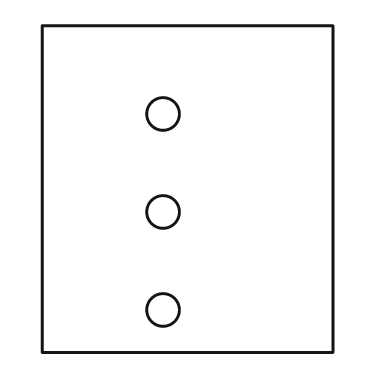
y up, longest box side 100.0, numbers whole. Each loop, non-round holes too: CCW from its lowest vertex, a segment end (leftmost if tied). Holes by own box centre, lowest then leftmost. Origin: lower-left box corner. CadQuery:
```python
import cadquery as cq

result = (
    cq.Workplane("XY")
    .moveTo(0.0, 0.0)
    .lineTo(89.0, 0.0)
    .lineTo(89.0, 100.0)
    .lineTo(0.0, 100.0)
    .close()
    .moveTo(37.0, 13.0)
    .circle(5.0)
    .moveTo(37.0, 43.0)
    .circle(5.0)
    .moveTo(37.0, 73.0)
    .circle(5.0)
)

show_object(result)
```